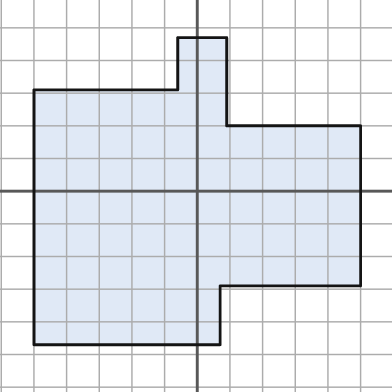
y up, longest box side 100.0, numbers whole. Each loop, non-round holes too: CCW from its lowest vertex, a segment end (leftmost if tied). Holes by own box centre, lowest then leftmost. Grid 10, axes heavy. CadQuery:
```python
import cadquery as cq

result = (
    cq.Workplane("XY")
    .moveTo(-50.0, -47.0)
    .lineTo(7.0, -47.0)
    .lineTo(7.0, -29.0)
    .lineTo(50.0, -29.0)
    .lineTo(50.0, 20.0)
    .lineTo(9.0, 20.0)
    .lineTo(9.0, 47.0)
    .lineTo(-6.0, 47.0)
    .lineTo(-6.0, 31.0)
    .lineTo(-50.0, 31.0)
    .close()
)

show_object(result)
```